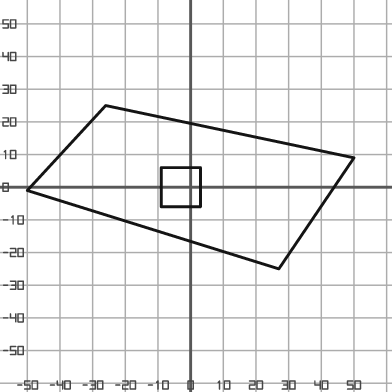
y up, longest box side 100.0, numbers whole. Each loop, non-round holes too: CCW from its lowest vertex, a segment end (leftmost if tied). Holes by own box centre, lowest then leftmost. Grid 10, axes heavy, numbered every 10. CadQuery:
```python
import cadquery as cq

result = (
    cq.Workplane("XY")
    .moveTo(27.0, -25.0)
    .lineTo(50.0, 9.0)
    .lineTo(-26.0, 25.0)
    .lineTo(-50.0, -1.0)
    .close()
    .moveTo(-9.0, -6.0)
    .lineTo(3.0, -6.0)
    .lineTo(3.0, 6.0)
    .lineTo(-9.0, 6.0)
    .close()
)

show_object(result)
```